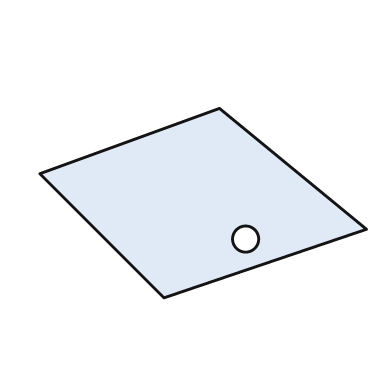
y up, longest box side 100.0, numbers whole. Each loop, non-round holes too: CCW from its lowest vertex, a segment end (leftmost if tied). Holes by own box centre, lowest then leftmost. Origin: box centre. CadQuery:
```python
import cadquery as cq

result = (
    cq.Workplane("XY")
    .moveTo(-12.0, -29.0)
    .lineTo(50.0, -8.0)
    .lineTo(5.0, 29.0)
    .lineTo(-50.0, 9.0)
    .close()
    .moveTo(13.0, -11.0)
    .circle(4.0)
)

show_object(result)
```